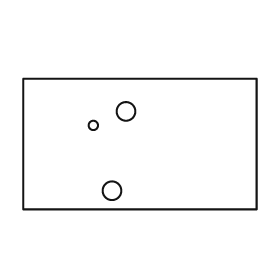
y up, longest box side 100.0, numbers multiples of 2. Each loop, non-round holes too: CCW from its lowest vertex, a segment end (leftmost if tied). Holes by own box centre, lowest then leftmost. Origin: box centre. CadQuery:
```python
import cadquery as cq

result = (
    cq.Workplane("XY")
    .moveTo(-50.0, -28.0)
    .lineTo(50.0, -28.0)
    .lineTo(50.0, 28.0)
    .lineTo(-50.0, 28.0)
    .close()
    .moveTo(-12.0, -20.0)
    .circle(4.0)
    .moveTo(-20.0, 8.0)
    .circle(2.0)
    .moveTo(-6.0, 14.0)
    .circle(4.0)
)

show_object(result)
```